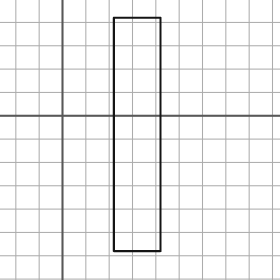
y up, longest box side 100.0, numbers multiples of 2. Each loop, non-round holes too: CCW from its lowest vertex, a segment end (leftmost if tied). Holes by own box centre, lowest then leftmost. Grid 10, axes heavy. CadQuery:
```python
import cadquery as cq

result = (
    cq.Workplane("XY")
    .moveTo(22.0, -58.0)
    .lineTo(42.0, -58.0)
    .lineTo(42.0, 42.0)
    .lineTo(22.0, 42.0)
    .close()
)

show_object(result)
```